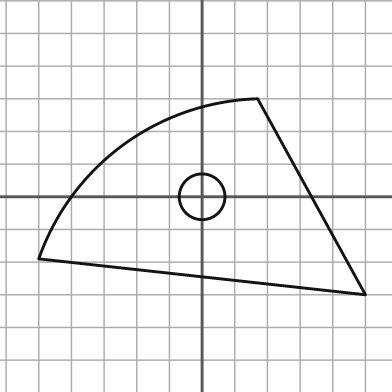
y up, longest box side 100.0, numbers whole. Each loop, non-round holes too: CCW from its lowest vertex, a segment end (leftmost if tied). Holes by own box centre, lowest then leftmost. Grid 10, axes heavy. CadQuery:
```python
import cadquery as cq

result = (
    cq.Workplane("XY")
    .moveTo(50.0, -30.0)
    .lineTo(17.0, 30.0)
    .threePointArc((-24.0, 16.0), (-50.0, -19.0))
    .close()
    .moveTo(0.0, 0.0)
    .circle(7.0)
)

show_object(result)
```